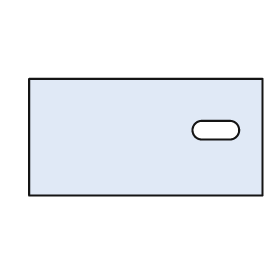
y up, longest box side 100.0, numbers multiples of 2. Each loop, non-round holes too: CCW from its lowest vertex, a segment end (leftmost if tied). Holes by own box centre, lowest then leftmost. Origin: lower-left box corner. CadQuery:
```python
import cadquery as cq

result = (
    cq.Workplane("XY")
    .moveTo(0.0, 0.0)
    .lineTo(100.0, 0.0)
    .lineTo(100.0, 50.0)
    .lineTo(0.0, 50.0)
    .close()
    .moveTo(74.0, 24.0)
    .lineTo(86.0, 24.0)
    .threePointArc((90.0, 28.0), (86.0, 32.0))
    .lineTo(74.0, 32.0)
    .threePointArc((70.0, 28.0), (74.0, 24.0))
    .close()
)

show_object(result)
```